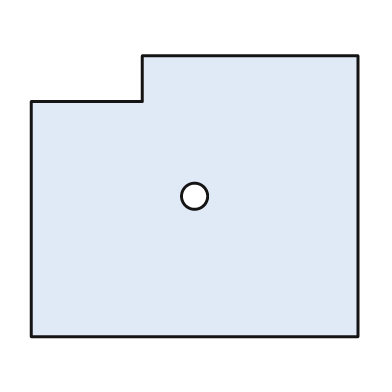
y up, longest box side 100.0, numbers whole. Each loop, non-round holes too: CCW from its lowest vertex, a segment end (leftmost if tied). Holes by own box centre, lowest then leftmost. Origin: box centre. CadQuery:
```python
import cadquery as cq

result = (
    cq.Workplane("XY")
    .moveTo(-50.0, -43.0)
    .lineTo(50.0, -43.0)
    .lineTo(50.0, 43.0)
    .lineTo(-16.0, 43.0)
    .lineTo(-16.0, 29.0)
    .lineTo(-50.0, 29.0)
    .close()
    .moveTo(0.0, 0.0)
    .circle(4.0)
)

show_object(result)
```